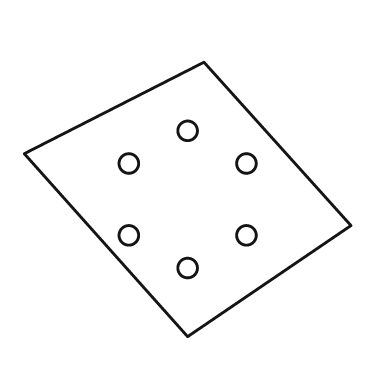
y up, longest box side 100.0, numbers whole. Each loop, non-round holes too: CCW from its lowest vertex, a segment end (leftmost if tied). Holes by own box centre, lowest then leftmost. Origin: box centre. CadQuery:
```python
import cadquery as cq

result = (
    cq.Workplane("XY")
    .moveTo(0.0, -42.0)
    .lineTo(50.0, -8.0)
    .lineTo(5.0, 42.0)
    .lineTo(-50.0, 14.0)
    .close()
    .moveTo(0.0, -21.0)
    .circle(3.0)
    .moveTo(-18.0, -11.0)
    .circle(3.0)
    .moveTo(18.0, -11.0)
    .circle(3.0)
    .moveTo(-18.0, 11.0)
    .circle(3.0)
    .moveTo(18.0, 11.0)
    .circle(3.0)
    .moveTo(0.0, 21.0)
    .circle(3.0)
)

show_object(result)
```